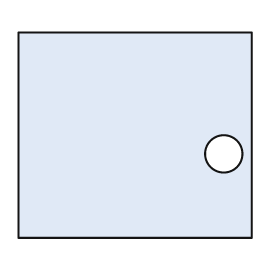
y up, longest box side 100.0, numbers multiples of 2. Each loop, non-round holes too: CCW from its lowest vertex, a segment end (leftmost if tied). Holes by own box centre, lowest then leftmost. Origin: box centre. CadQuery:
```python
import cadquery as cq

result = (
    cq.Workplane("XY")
    .moveTo(-50.0, -44.0)
    .lineTo(50.0, -44.0)
    .lineTo(50.0, 44.0)
    .lineTo(-50.0, 44.0)
    .close()
    .moveTo(38.0, -8.0)
    .circle(8.0)
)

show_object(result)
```